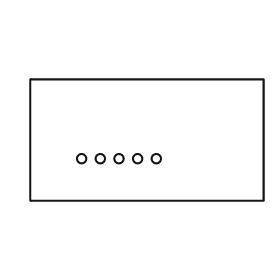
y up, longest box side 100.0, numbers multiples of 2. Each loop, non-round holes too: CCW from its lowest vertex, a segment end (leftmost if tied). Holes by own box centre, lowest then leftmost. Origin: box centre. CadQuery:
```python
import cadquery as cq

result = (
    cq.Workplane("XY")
    .moveTo(-50.0, -26.0)
    .lineTo(50.0, -26.0)
    .lineTo(50.0, 26.0)
    .lineTo(-50.0, 26.0)
    .close()
    .moveTo(-28.0, -8.0)
    .circle(2.0)
    .moveTo(-20.0, -8.0)
    .circle(2.0)
    .moveTo(-12.0, -8.0)
    .circle(2.0)
    .moveTo(-4.0, -8.0)
    .circle(2.0)
    .moveTo(4.0, -8.0)
    .circle(2.0)
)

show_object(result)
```